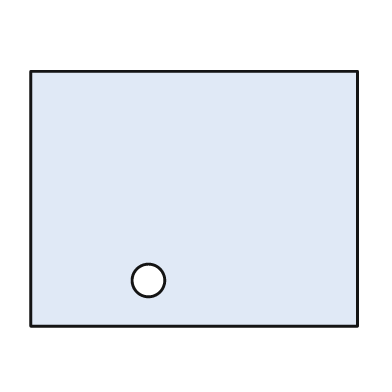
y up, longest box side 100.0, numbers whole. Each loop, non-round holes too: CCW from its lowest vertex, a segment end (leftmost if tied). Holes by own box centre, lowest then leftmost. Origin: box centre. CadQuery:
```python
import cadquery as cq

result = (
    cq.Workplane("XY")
    .moveTo(-50.0, -39.0)
    .lineTo(50.0, -39.0)
    .lineTo(50.0, 39.0)
    .lineTo(-50.0, 39.0)
    .close()
    .moveTo(-14.0, -25.0)
    .circle(5.0)
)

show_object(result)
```